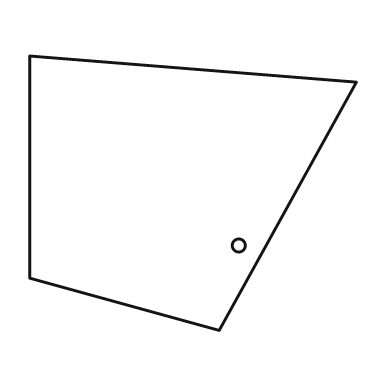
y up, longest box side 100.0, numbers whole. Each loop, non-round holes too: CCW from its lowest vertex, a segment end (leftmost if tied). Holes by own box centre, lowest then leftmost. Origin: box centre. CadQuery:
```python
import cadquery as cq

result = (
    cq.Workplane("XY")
    .moveTo(8.0, -42.0)
    .lineTo(50.0, 34.0)
    .lineTo(-50.0, 42.0)
    .lineTo(-50.0, -26.0)
    .close()
    .moveTo(14.0, -16.0)
    .circle(2.0)
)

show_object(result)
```